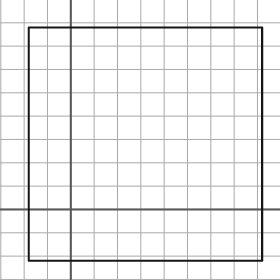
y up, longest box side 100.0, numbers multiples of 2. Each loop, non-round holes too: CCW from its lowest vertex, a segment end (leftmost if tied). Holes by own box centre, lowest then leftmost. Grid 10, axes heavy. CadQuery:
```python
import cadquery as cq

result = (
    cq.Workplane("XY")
    .moveTo(-18.0, -22.0)
    .lineTo(82.0, -22.0)
    .lineTo(82.0, 78.0)
    .lineTo(-18.0, 78.0)
    .close()
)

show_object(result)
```